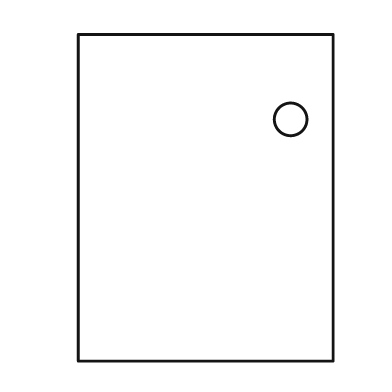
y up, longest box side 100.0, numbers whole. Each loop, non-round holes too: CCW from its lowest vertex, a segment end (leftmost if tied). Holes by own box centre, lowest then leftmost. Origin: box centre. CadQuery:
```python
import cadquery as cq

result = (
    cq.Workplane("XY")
    .moveTo(-39.0, -50.0)
    .lineTo(39.0, -50.0)
    .lineTo(39.0, 50.0)
    .lineTo(-39.0, 50.0)
    .close()
    .moveTo(26.0, 24.0)
    .circle(5.0)
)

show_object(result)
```